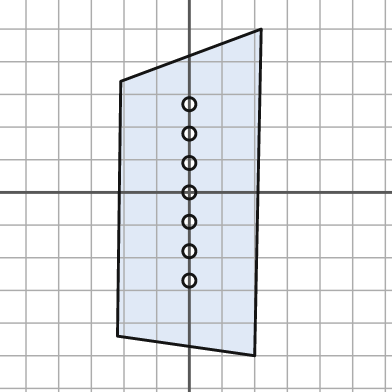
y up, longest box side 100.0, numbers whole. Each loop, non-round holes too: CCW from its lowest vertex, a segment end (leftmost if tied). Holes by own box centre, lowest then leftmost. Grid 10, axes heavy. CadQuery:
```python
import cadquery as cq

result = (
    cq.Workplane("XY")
    .moveTo(20.0, -50.0)
    .lineTo(22.0, 50.0)
    .lineTo(-21.0, 34.0)
    .lineTo(-22.0, -44.0)
    .close()
    .moveTo(0.0, -27.0)
    .circle(2.0)
    .moveTo(0.0, -18.0)
    .circle(2.0)
    .moveTo(0.0, -9.0)
    .circle(2.0)
    .moveTo(0.0, 0.0)
    .circle(2.0)
    .moveTo(0.0, 9.0)
    .circle(2.0)
    .moveTo(0.0, 18.0)
    .circle(2.0)
    .moveTo(0.0, 27.0)
    .circle(2.0)
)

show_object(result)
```